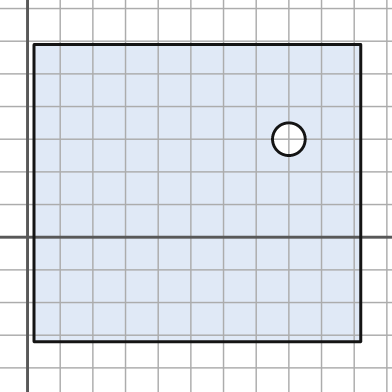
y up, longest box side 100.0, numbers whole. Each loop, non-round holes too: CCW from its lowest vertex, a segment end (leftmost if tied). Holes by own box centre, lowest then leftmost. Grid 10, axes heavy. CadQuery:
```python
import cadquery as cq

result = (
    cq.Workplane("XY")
    .moveTo(2.0, -32.0)
    .lineTo(102.0, -32.0)
    .lineTo(102.0, 59.0)
    .lineTo(2.0, 59.0)
    .close()
    .moveTo(80.0, 30.0)
    .circle(5.0)
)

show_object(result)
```